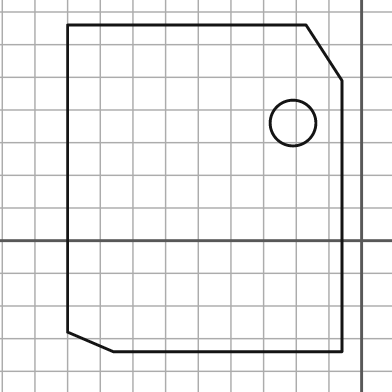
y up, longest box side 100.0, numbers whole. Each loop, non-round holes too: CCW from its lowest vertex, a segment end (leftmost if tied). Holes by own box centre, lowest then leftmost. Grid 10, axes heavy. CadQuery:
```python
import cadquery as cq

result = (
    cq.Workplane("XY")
    .moveTo(-76.0, -34.0)
    .lineTo(-6.0, -34.0)
    .lineTo(-6.0, 49.0)
    .lineTo(-17.0, 66.0)
    .lineTo(-90.0, 66.0)
    .lineTo(-90.0, -28.0)
    .close()
    .moveTo(-21.0, 36.0)
    .circle(7.0)
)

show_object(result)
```